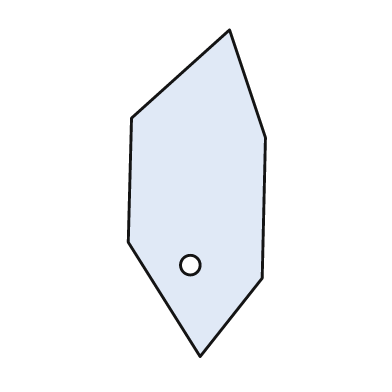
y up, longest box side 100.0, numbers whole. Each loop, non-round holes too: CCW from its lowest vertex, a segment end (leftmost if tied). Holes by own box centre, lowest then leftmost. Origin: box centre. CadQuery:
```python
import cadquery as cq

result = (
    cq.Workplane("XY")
    .moveTo(1.0, -50.0)
    .lineTo(20.0, -26.0)
    .lineTo(21.0, 17.0)
    .lineTo(10.0, 50.0)
    .lineTo(-20.0, 23.0)
    .lineTo(-21.0, -15.0)
    .close()
    .moveTo(-2.0, -22.0)
    .circle(3.0)
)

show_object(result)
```